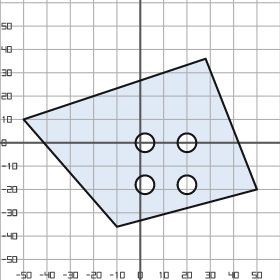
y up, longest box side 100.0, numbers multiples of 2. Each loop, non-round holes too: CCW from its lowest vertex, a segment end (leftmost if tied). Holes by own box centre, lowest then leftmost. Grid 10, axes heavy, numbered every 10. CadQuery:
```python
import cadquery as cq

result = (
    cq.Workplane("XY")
    .moveTo(-10.0, -36.0)
    .lineTo(50.0, -20.0)
    .lineTo(28.0, 36.0)
    .lineTo(-50.0, 10.0)
    .close()
    .moveTo(2.0, -18.0)
    .circle(4.0)
    .moveTo(20.0, -18.0)
    .circle(4.0)
    .moveTo(2.0, 0.0)
    .circle(4.0)
    .moveTo(20.0, 0.0)
    .circle(4.0)
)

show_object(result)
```